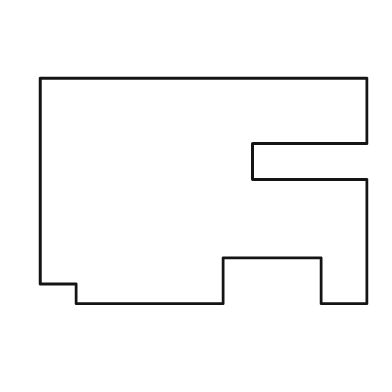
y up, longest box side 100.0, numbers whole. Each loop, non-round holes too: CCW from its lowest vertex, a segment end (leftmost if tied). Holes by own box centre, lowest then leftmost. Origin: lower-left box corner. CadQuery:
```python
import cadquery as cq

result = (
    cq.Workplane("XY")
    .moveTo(11.0, 0.0)
    .lineTo(56.0, 0.0)
    .lineTo(56.0, 14.0)
    .lineTo(86.0, 14.0)
    .lineTo(86.0, 0.0)
    .lineTo(100.0, 0.0)
    .lineTo(100.0, 38.0)
    .lineTo(65.0, 38.0)
    .lineTo(65.0, 49.0)
    .lineTo(100.0, 49.0)
    .lineTo(100.0, 69.0)
    .lineTo(0.0, 69.0)
    .lineTo(0.0, 6.0)
    .lineTo(11.0, 6.0)
    .close()
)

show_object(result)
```